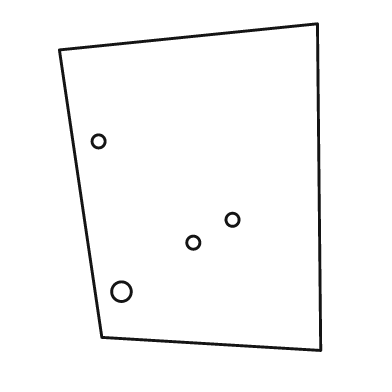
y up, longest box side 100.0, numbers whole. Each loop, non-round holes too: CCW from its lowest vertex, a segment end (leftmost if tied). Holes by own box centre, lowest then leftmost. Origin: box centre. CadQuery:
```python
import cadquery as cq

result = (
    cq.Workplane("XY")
    .moveTo(40.0, -50.0)
    .lineTo(39.0, 50.0)
    .lineTo(-40.0, 42.0)
    .lineTo(-27.0, -46.0)
    .close()
    .moveTo(-21.0, -32.0)
    .circle(3.0)
    .moveTo(1.0, -17.0)
    .circle(2.0)
    .moveTo(13.0, -10.0)
    .circle(2.0)
    .moveTo(-28.0, 14.0)
    .circle(2.0)
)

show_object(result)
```